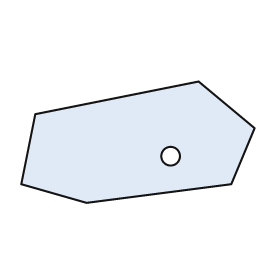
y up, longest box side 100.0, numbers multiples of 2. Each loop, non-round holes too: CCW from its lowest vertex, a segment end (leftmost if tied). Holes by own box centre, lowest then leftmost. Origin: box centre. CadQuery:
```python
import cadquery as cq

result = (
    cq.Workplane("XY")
    .moveTo(-22.0, -26.0)
    .lineTo(40.0, -18.0)
    .lineTo(50.0, 6.0)
    .lineTo(26.0, 26.0)
    .lineTo(-44.0, 12.0)
    .lineTo(-50.0, -18.0)
    .close()
    .moveTo(14.0, -6.0)
    .circle(4.0)
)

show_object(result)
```